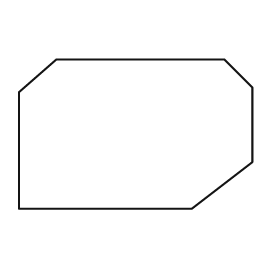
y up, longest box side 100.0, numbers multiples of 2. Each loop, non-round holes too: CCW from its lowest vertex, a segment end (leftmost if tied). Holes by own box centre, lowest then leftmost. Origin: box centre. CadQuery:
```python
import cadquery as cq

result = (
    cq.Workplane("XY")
    .moveTo(-50.0, -32.0)
    .lineTo(24.0, -32.0)
    .lineTo(50.0, -12.0)
    .lineTo(50.0, 20.0)
    .lineTo(38.0, 32.0)
    .lineTo(-34.0, 32.0)
    .lineTo(-50.0, 18.0)
    .close()
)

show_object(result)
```